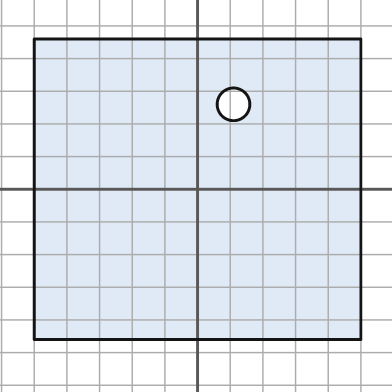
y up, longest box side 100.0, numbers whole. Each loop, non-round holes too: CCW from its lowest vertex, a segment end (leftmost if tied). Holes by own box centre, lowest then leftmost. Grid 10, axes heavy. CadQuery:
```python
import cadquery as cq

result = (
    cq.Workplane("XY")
    .moveTo(-50.0, -46.0)
    .lineTo(50.0, -46.0)
    .lineTo(50.0, 46.0)
    .lineTo(-50.0, 46.0)
    .close()
    .moveTo(11.0, 26.0)
    .circle(5.0)
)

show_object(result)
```